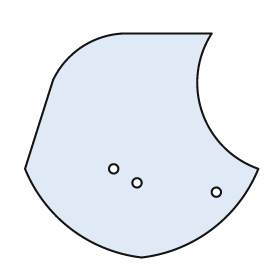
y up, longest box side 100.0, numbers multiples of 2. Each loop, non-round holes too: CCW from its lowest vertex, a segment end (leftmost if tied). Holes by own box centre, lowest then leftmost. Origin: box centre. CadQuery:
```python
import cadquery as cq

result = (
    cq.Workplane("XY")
    .moveTo(0.0, -48.0)
    .threePointArc((30.0, -36.0), (50.0, -10.0))
    .threePointArc((26.0, 14.0), (30.0, 48.0))
    .lineTo(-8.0, 48.0)
    .threePointArc((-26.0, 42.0), (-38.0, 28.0))
    .lineTo(-50.0, -10.0)
    .threePointArc((-30.0, -36.0), (0.0, -48.0))
    .close()
    .moveTo(32.0, -20.0)
    .circle(2.0)
    .moveTo(-2.0, -16.0)
    .circle(2.0)
    .moveTo(-12.0, -10.0)
    .circle(2.0)
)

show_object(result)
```